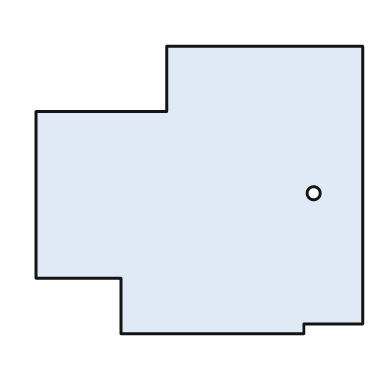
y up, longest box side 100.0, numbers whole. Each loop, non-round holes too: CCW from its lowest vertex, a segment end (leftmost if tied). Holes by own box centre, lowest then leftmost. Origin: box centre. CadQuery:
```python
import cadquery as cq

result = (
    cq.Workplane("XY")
    .moveTo(-24.0, -44.0)
    .lineTo(32.0, -44.0)
    .lineTo(32.0, -41.0)
    .lineTo(50.0, -41.0)
    .lineTo(50.0, 44.0)
    .lineTo(-10.0, 44.0)
    .lineTo(-10.0, 24.0)
    .lineTo(-50.0, 24.0)
    .lineTo(-50.0, -27.0)
    .lineTo(-24.0, -27.0)
    .close()
    .moveTo(35.0, -1.0)
    .circle(2.0)
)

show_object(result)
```